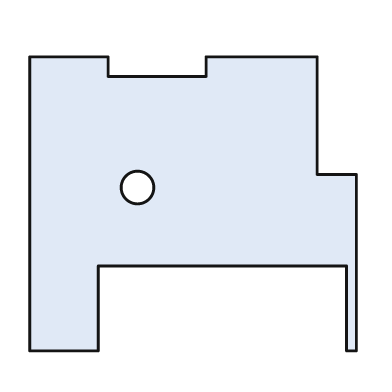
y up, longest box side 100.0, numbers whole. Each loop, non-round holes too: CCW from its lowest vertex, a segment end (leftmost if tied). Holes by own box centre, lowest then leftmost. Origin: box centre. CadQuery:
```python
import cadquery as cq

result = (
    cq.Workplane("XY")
    .moveTo(-50.0, -45.0)
    .lineTo(-29.0, -45.0)
    .lineTo(-29.0, -19.0)
    .lineTo(47.0, -19.0)
    .lineTo(47.0, -45.0)
    .lineTo(50.0, -45.0)
    .lineTo(50.0, 9.0)
    .lineTo(38.0, 9.0)
    .lineTo(38.0, 45.0)
    .lineTo(4.0, 45.0)
    .lineTo(4.0, 39.0)
    .lineTo(-26.0, 39.0)
    .lineTo(-26.0, 45.0)
    .lineTo(-50.0, 45.0)
    .close()
    .moveTo(-17.0, 5.0)
    .circle(5.0)
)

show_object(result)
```